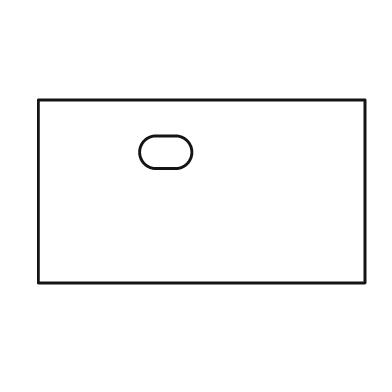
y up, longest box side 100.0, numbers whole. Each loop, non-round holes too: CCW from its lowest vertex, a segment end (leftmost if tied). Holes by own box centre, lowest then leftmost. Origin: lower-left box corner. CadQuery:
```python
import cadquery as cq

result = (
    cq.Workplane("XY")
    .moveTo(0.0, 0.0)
    .lineTo(100.0, 0.0)
    .lineTo(100.0, 56.0)
    .lineTo(0.0, 56.0)
    .close()
    .moveTo(36.0, 35.0)
    .lineTo(42.0, 35.0)
    .threePointArc((47.0, 40.0), (42.0, 45.0))
    .lineTo(36.0, 45.0)
    .threePointArc((31.0, 40.0), (36.0, 35.0))
    .close()
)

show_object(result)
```